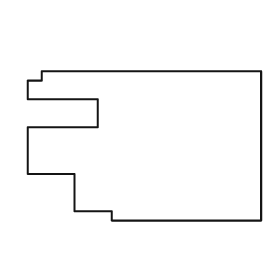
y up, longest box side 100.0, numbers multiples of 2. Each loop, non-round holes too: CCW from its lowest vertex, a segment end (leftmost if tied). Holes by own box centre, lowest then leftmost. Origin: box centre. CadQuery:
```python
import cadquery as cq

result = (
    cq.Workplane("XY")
    .moveTo(-14.0, -32.0)
    .lineTo(50.0, -32.0)
    .lineTo(50.0, 32.0)
    .lineTo(-44.0, 32.0)
    .lineTo(-44.0, 28.0)
    .lineTo(-50.0, 28.0)
    .lineTo(-50.0, 20.0)
    .lineTo(-20.0, 20.0)
    .lineTo(-20.0, 8.0)
    .lineTo(-50.0, 8.0)
    .lineTo(-50.0, -12.0)
    .lineTo(-30.0, -12.0)
    .lineTo(-30.0, -28.0)
    .lineTo(-14.0, -28.0)
    .close()
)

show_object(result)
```